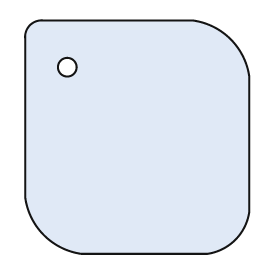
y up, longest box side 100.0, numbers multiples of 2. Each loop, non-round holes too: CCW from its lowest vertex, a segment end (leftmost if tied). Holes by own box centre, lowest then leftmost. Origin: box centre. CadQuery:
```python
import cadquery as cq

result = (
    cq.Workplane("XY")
    .moveTo(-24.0, -50.0)
    .lineTo(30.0, -50.0)
    .threePointArc((42.0, -44.0), (48.0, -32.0))
    .lineTo(48.0, 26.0)
    .threePointArc((40.0, 42.0), (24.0, 50.0))
    .lineTo(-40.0, 50.0)
    .threePointArc((-46.0, 48.0), (-48.0, 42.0))
    .lineTo(-48.0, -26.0)
    .threePointArc((-40.0, -42.0), (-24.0, -50.0))
    .close()
    .moveTo(-30.0, 30.0)
    .circle(4.0)
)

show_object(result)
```